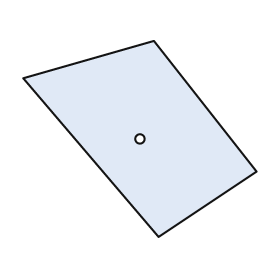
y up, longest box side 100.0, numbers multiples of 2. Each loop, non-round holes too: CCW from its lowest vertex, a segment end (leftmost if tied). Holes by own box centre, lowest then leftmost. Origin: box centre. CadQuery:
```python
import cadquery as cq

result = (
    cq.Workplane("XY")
    .moveTo(8.0, -42.0)
    .lineTo(50.0, -14.0)
    .lineTo(6.0, 42.0)
    .lineTo(-50.0, 26.0)
    .close()
    .moveTo(0.0, 0.0)
    .circle(2.0)
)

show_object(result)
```